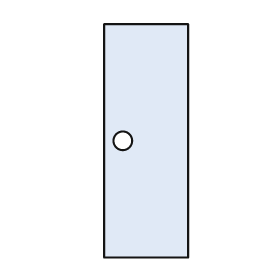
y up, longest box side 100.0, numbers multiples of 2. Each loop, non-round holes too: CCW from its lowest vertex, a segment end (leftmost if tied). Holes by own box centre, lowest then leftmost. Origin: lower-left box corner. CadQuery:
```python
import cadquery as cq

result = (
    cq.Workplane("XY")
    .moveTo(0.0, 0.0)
    .lineTo(36.0, 0.0)
    .lineTo(36.0, 100.0)
    .lineTo(0.0, 100.0)
    .close()
    .moveTo(8.0, 50.0)
    .circle(4.0)
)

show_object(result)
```